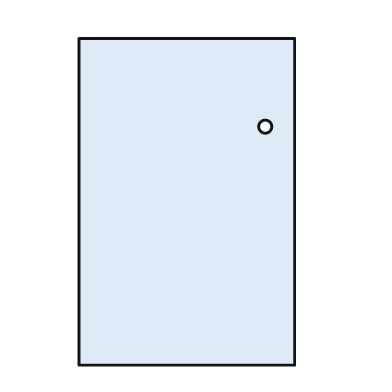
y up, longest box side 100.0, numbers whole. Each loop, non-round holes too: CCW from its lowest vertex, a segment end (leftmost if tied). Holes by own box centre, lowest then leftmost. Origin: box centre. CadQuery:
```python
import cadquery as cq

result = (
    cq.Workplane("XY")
    .moveTo(-33.0, -50.0)
    .lineTo(33.0, -50.0)
    .lineTo(33.0, 50.0)
    .lineTo(-33.0, 50.0)
    .close()
    .moveTo(24.0, 23.0)
    .circle(2.0)
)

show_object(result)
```